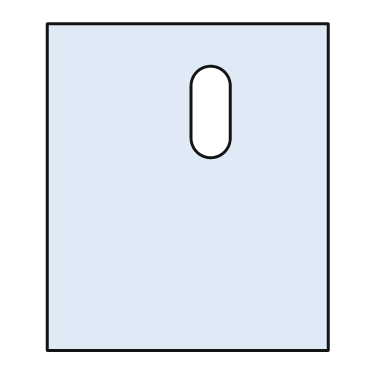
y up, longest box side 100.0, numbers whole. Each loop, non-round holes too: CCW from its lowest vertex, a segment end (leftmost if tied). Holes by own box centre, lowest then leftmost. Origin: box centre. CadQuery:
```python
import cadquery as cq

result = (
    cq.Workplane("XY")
    .moveTo(-43.0, -50.0)
    .lineTo(43.0, -50.0)
    .lineTo(43.0, 50.0)
    .lineTo(-43.0, 50.0)
    .close()
    .moveTo(1.0, 15.0)
    .threePointArc((7.0, 9.0), (13.0, 15.0))
    .lineTo(13.0, 31.0)
    .threePointArc((7.0, 37.0), (1.0, 31.0))
    .close()
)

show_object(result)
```